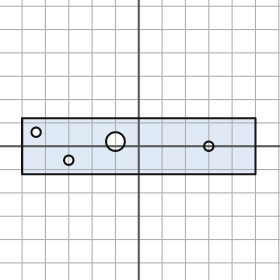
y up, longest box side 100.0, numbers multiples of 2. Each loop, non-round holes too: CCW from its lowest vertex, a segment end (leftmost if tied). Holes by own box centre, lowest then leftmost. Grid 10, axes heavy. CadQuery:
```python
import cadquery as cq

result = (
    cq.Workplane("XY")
    .moveTo(-50.0, -12.0)
    .lineTo(50.0, -12.0)
    .lineTo(50.0, 12.0)
    .lineTo(-50.0, 12.0)
    .close()
    .moveTo(-30.0, -6.0)
    .circle(2.0)
    .moveTo(30.0, 0.0)
    .circle(2.0)
    .moveTo(-10.0, 2.0)
    .circle(4.0)
    .moveTo(-44.0, 6.0)
    .circle(2.0)
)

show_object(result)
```